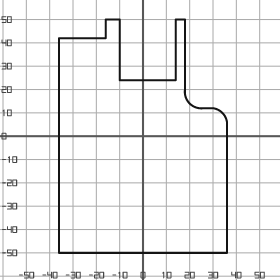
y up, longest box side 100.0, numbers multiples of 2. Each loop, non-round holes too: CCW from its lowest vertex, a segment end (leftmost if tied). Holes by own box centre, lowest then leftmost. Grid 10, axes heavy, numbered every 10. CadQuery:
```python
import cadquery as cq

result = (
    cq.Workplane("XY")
    .moveTo(-36.0, -50.0)
    .lineTo(36.0, -50.0)
    .lineTo(36.0, 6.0)
    .threePointArc((34.0, 10.0), (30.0, 12.0))
    .lineTo(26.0, 12.0)
    .threePointArc((20.0, 14.0), (18.0, 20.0))
    .lineTo(18.0, 50.0)
    .lineTo(14.0, 50.0)
    .lineTo(14.0, 24.0)
    .lineTo(-10.0, 24.0)
    .lineTo(-10.0, 50.0)
    .lineTo(-16.0, 50.0)
    .lineTo(-16.0, 42.0)
    .lineTo(-36.0, 42.0)
    .close()
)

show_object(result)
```